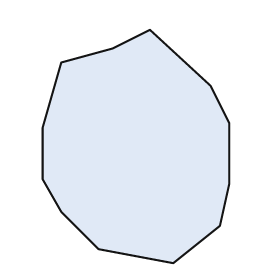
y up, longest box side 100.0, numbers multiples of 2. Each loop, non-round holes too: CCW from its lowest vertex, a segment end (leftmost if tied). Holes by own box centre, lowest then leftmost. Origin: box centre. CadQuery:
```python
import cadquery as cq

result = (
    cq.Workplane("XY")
    .moveTo(16.0, -50.0)
    .lineTo(36.0, -34.0)
    .lineTo(40.0, -16.0)
    .lineTo(40.0, 10.0)
    .lineTo(32.0, 26.0)
    .lineTo(6.0, 50.0)
    .lineTo(-10.0, 42.0)
    .lineTo(-32.0, 36.0)
    .lineTo(-40.0, 8.0)
    .lineTo(-40.0, -14.0)
    .lineTo(-32.0, -28.0)
    .lineTo(-16.0, -44.0)
    .close()
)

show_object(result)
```